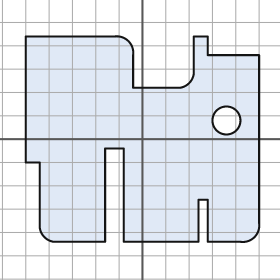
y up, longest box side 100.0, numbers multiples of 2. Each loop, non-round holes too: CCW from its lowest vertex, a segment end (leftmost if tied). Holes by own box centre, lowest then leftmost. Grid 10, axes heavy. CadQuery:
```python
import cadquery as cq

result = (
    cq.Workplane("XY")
    .moveTo(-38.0, -44.0)
    .lineTo(-16.0, -44.0)
    .lineTo(-16.0, -4.0)
    .lineTo(-8.0, -4.0)
    .lineTo(-8.0, -44.0)
    .lineTo(24.0, -44.0)
    .lineTo(24.0, -26.0)
    .lineTo(28.0, -26.0)
    .lineTo(28.0, -44.0)
    .lineTo(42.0, -44.0)
    .threePointArc((48.0, -42.0), (50.0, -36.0))
    .lineTo(50.0, 36.0)
    .lineTo(28.0, 36.0)
    .lineTo(28.0, 44.0)
    .lineTo(22.0, 44.0)
    .lineTo(22.0, 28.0)
    .threePointArc((20.0, 24.0), (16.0, 22.0))
    .lineTo(-4.0, 22.0)
    .lineTo(-4.0, 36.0)
    .threePointArc((-6.0, 42.0), (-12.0, 44.0))
    .lineTo(-50.0, 44.0)
    .lineTo(-50.0, -10.0)
    .lineTo(-44.0, -10.0)
    .lineTo(-44.0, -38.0)
    .threePointArc((-42.0, -42.0), (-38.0, -44.0))
    .close()
    .moveTo(36.0, 8.0)
    .circle(6.0)
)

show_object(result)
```